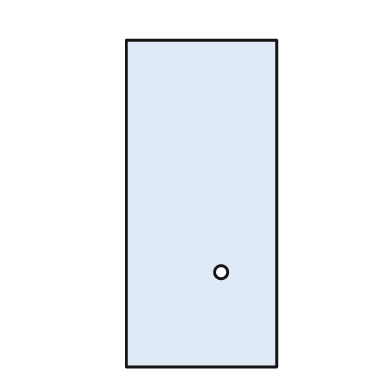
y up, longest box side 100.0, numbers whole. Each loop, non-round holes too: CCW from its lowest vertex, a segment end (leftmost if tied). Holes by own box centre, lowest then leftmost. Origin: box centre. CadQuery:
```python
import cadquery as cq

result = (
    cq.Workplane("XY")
    .moveTo(-23.0, -50.0)
    .lineTo(23.0, -50.0)
    .lineTo(23.0, 50.0)
    .lineTo(-23.0, 50.0)
    .close()
    .moveTo(6.0, -21.0)
    .circle(2.0)
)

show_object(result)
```